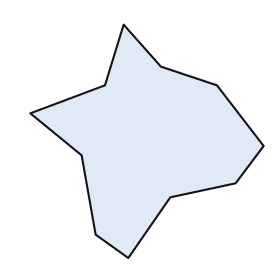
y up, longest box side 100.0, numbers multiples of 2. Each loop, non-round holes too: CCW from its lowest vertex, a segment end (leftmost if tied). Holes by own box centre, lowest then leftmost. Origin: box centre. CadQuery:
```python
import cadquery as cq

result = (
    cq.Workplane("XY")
    .moveTo(-8.0, -50.0)
    .lineTo(10.0, -24.0)
    .lineTo(38.0, -18.0)
    .lineTo(50.0, -2.0)
    .lineTo(30.0, 24.0)
    .lineTo(6.0, 32.0)
    .lineTo(-10.0, 50.0)
    .lineTo(-18.0, 24.0)
    .lineTo(-50.0, 12.0)
    .lineTo(-28.0, -6.0)
    .lineTo(-22.0, -40.0)
    .close()
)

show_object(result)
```